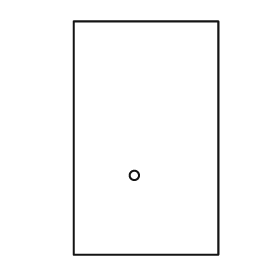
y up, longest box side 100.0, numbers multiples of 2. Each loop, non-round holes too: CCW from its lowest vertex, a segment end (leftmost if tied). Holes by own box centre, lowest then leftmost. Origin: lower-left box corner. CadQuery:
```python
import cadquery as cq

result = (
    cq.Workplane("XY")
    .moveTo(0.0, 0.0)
    .lineTo(62.0, 0.0)
    .lineTo(62.0, 100.0)
    .lineTo(0.0, 100.0)
    .close()
    .moveTo(26.0, 34.0)
    .circle(2.0)
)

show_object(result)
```